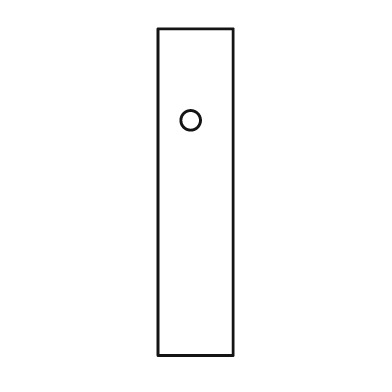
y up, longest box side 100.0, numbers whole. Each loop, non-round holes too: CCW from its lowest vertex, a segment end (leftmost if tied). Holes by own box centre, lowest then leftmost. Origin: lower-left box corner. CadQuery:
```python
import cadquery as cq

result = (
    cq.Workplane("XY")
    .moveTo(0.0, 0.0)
    .lineTo(23.0, 0.0)
    .lineTo(23.0, 100.0)
    .lineTo(0.0, 100.0)
    .close()
    .moveTo(10.0, 72.0)
    .circle(3.0)
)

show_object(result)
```